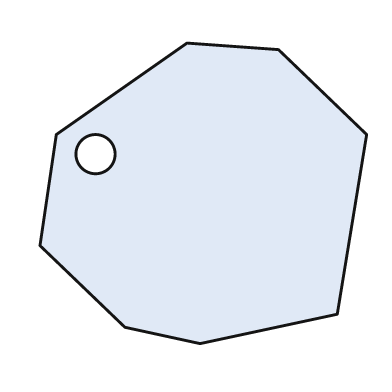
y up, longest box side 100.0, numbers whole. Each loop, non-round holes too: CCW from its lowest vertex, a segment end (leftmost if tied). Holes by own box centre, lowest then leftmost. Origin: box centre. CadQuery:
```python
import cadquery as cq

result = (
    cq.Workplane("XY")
    .moveTo(-1.0, -46.0)
    .lineTo(41.0, -37.0)
    .lineTo(50.0, 18.0)
    .lineTo(23.0, 44.0)
    .lineTo(-5.0, 46.0)
    .lineTo(-45.0, 18.0)
    .lineTo(-50.0, -16.0)
    .lineTo(-24.0, -41.0)
    .close()
    .moveTo(-33.0, 12.0)
    .circle(6.0)
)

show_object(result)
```